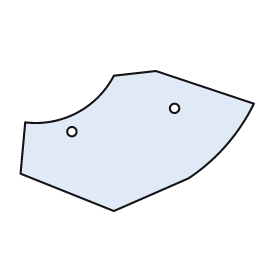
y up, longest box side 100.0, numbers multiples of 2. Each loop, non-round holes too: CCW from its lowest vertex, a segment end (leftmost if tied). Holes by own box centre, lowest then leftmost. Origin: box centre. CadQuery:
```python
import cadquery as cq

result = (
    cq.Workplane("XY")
    .moveTo(-10.0, -30.0)
    .lineTo(22.0, -16.0)
    .threePointArc((38.0, -2.0), (50.0, 16.0))
    .lineTo(8.0, 30.0)
    .lineTo(-10.0, 28.0)
    .threePointArc((-26.0, 12.0), (-48.0, 8.0))
    .lineTo(-50.0, -14.0)
    .close()
    .moveTo(-28.0, 4.0)
    .circle(2.0)
    .moveTo(16.0, 14.0)
    .circle(2.0)
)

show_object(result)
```